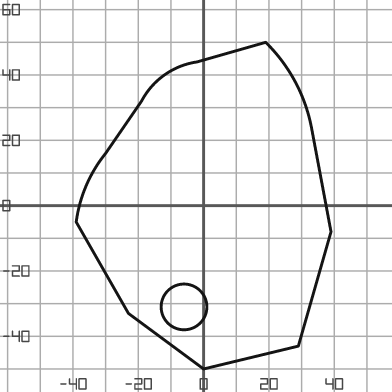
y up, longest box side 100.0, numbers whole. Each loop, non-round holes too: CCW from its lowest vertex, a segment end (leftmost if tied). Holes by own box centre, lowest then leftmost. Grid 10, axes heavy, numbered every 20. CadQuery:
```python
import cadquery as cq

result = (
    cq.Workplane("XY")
    .moveTo(0.0, -50.0)
    .lineTo(29.0, -43.0)
    .lineTo(39.0, -8.0)
    .lineTo(33.0, 24.0)
    .threePointArc((28.0, 38.0), (19.0, 50.0))
    .lineTo(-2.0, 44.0)
    .threePointArc((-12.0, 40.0), (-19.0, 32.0))
    .lineTo(-30.0, 16.0)
    .threePointArc((-36.0, 6.0), (-39.0, -5.0))
    .lineTo(-23.0, -33.0)
    .close()
    .moveTo(-6.0, -31.0)
    .circle(7.0)
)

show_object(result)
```